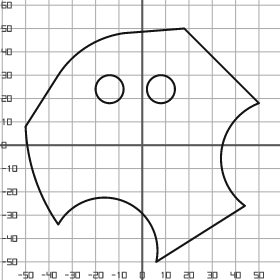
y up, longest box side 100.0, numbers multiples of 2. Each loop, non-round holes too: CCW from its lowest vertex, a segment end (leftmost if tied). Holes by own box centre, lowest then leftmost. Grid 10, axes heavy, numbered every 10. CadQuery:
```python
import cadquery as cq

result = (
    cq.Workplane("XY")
    .moveTo(6.0, -50.0)
    .lineTo(44.0, -26.0)
    .threePointArc((34.0, -2.0), (50.0, 18.0))
    .lineTo(18.0, 50.0)
    .lineTo(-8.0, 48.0)
    .threePointArc((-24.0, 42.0), (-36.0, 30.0))
    .lineTo(-50.0, 8.0)
    .threePointArc((-46.0, -14.0), (-36.0, -34.0))
    .threePointArc((-8.0, -24.0), (6.0, -50.0))
    .close()
    .moveTo(-14.0, 24.0)
    .circle(6.0)
    .moveTo(8.0, 24.0)
    .circle(6.0)
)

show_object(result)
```